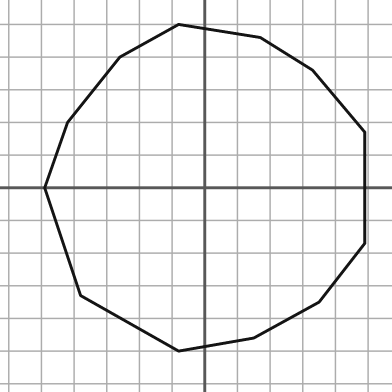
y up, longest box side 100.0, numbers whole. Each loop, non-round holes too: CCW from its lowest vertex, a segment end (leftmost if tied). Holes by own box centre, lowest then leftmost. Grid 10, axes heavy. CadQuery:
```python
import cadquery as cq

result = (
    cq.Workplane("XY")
    .moveTo(-8.0, -50.0)
    .lineTo(15.0, -46.0)
    .lineTo(35.0, -35.0)
    .lineTo(49.0, -17.0)
    .lineTo(49.0, 17.0)
    .lineTo(33.0, 36.0)
    .lineTo(17.0, 46.0)
    .lineTo(-8.0, 50.0)
    .lineTo(-26.0, 40.0)
    .lineTo(-42.0, 20.0)
    .lineTo(-49.0, 0.0)
    .lineTo(-38.0, -33.0)
    .close()
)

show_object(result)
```